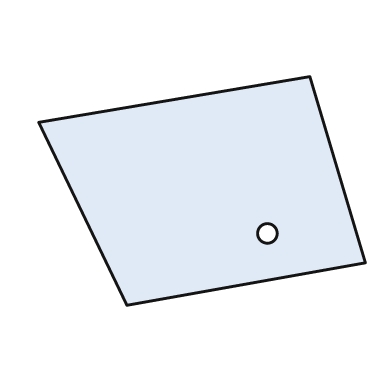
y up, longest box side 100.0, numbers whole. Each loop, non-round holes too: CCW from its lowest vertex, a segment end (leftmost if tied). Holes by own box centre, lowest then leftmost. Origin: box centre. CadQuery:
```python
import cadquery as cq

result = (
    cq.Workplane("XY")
    .moveTo(-23.0, -35.0)
    .lineTo(50.0, -22.0)
    .lineTo(33.0, 35.0)
    .lineTo(-50.0, 21.0)
    .close()
    .moveTo(20.0, -13.0)
    .circle(3.0)
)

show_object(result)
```